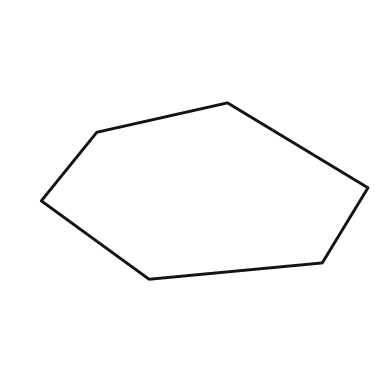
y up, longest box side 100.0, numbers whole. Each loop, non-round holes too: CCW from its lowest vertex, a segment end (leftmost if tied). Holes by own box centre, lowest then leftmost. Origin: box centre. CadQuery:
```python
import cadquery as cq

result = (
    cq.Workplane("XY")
    .moveTo(-17.0, -27.0)
    .lineTo(36.0, -22.0)
    .lineTo(50.0, 1.0)
    .lineTo(7.0, 27.0)
    .lineTo(-33.0, 18.0)
    .lineTo(-50.0, -3.0)
    .close()
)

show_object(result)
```